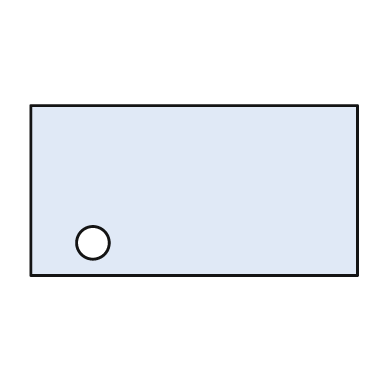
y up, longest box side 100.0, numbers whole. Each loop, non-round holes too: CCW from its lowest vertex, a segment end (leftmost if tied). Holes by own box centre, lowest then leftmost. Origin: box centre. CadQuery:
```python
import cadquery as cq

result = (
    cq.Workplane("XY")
    .moveTo(-50.0, -26.0)
    .lineTo(50.0, -26.0)
    .lineTo(50.0, 26.0)
    .lineTo(-50.0, 26.0)
    .close()
    .moveTo(-31.0, -16.0)
    .circle(5.0)
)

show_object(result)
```